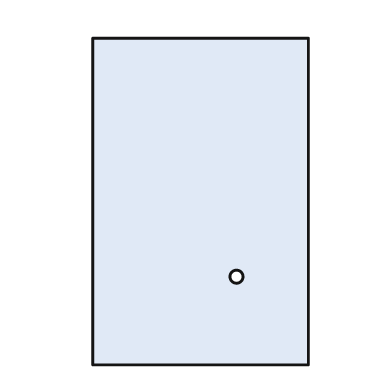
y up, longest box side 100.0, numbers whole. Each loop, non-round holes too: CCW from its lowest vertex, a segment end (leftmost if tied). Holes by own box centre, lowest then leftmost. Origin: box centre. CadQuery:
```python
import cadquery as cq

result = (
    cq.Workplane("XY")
    .moveTo(-33.0, -50.0)
    .lineTo(33.0, -50.0)
    .lineTo(33.0, 50.0)
    .lineTo(-33.0, 50.0)
    .close()
    .moveTo(11.0, -23.0)
    .circle(2.0)
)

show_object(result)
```